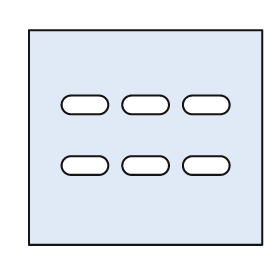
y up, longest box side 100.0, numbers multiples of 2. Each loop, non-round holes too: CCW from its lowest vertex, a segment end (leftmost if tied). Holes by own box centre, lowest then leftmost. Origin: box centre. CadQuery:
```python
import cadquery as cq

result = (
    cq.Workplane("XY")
    .moveTo(-50.0, -46.0)
    .lineTo(50.0, -46.0)
    .lineTo(50.0, 46.0)
    .lineTo(-50.0, 46.0)
    .close()
    .moveTo(-32.0, -16.0)
    .lineTo(-20.0, -16.0)
    .threePointArc((-16.0, -12.0), (-20.0, -8.0))
    .lineTo(-32.0, -8.0)
    .threePointArc((-36.0, -12.0), (-32.0, -16.0))
    .close()
    .moveTo(-6.0, -16.0)
    .lineTo(6.0, -16.0)
    .threePointArc((10.0, -12.0), (6.0, -8.0))
    .lineTo(-6.0, -8.0)
    .threePointArc((-10.0, -12.0), (-6.0, -16.0))
    .close()
    .moveTo(20.0, -16.0)
    .lineTo(32.0, -16.0)
    .threePointArc((36.0, -12.0), (32.0, -8.0))
    .lineTo(20.0, -8.0)
    .threePointArc((16.0, -12.0), (20.0, -16.0))
    .close()
    .moveTo(-32.0, 10.0)
    .lineTo(-20.0, 10.0)
    .threePointArc((-16.0, 14.0), (-20.0, 18.0))
    .lineTo(-32.0, 18.0)
    .threePointArc((-36.0, 14.0), (-32.0, 10.0))
    .close()
    .moveTo(-6.0, 10.0)
    .lineTo(6.0, 10.0)
    .threePointArc((10.0, 14.0), (6.0, 18.0))
    .lineTo(-6.0, 18.0)
    .threePointArc((-10.0, 14.0), (-6.0, 10.0))
    .close()
    .moveTo(20.0, 10.0)
    .lineTo(32.0, 10.0)
    .threePointArc((36.0, 14.0), (32.0, 18.0))
    .lineTo(20.0, 18.0)
    .threePointArc((16.0, 14.0), (20.0, 10.0))
    .close()
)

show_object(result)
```